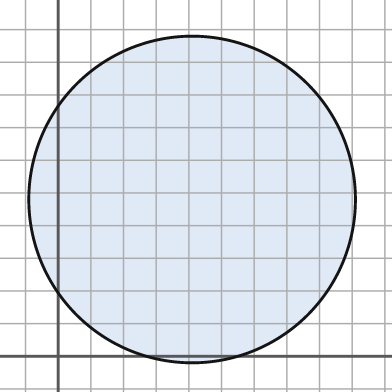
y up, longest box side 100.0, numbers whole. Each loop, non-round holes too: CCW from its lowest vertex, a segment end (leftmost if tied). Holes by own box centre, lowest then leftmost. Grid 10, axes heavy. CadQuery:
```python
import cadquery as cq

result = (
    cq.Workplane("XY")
    .moveTo(41.0, 48.0)
    .circle(50.0)
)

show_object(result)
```